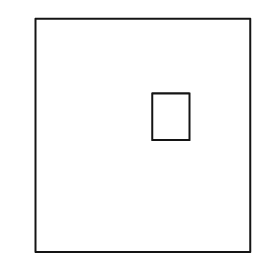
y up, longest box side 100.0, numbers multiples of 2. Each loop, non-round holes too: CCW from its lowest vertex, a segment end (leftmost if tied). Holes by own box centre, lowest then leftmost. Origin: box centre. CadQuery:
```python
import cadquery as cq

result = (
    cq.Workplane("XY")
    .moveTo(-46.0, -50.0)
    .lineTo(46.0, -50.0)
    .lineTo(46.0, 50.0)
    .lineTo(-46.0, 50.0)
    .close()
    .moveTo(4.0, -2.0)
    .lineTo(20.0, -2.0)
    .lineTo(20.0, 18.0)
    .lineTo(4.0, 18.0)
    .close()
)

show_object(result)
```